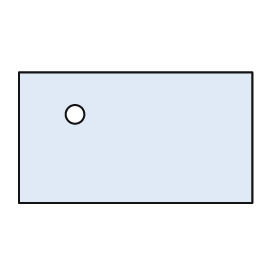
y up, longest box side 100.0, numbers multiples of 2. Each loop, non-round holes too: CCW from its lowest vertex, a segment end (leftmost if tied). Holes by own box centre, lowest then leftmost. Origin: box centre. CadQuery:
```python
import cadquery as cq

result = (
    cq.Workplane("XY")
    .moveTo(-50.0, -28.0)
    .lineTo(50.0, -28.0)
    .lineTo(50.0, 28.0)
    .lineTo(-50.0, 28.0)
    .close()
    .moveTo(-26.0, 10.0)
    .circle(4.0)
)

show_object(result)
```